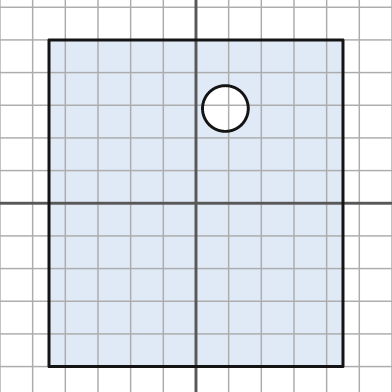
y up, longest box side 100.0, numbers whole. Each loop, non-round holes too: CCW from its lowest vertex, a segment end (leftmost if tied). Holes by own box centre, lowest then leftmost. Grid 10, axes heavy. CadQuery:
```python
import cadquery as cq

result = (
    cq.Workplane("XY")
    .moveTo(-45.0, -50.0)
    .lineTo(45.0, -50.0)
    .lineTo(45.0, 50.0)
    .lineTo(-45.0, 50.0)
    .close()
    .moveTo(9.0, 29.0)
    .circle(7.0)
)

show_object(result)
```